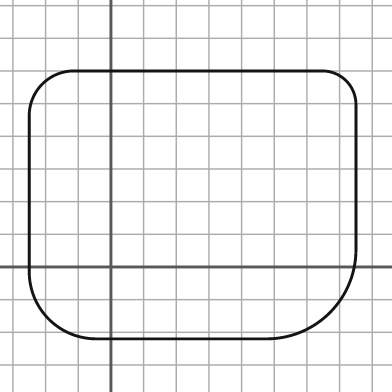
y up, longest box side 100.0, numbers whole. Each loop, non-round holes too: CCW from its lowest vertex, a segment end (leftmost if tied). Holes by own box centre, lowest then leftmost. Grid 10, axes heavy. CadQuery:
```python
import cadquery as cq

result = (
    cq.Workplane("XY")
    .moveTo(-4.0, -22.0)
    .lineTo(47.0, -22.0)
    .threePointArc((67.0, -14.0), (75.0, 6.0))
    .lineTo(75.0, 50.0)
    .threePointArc((72.0, 57.0), (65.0, 60.0))
    .lineTo(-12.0, 60.0)
    .threePointArc((-21.0, 56.0), (-25.0, 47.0))
    .lineTo(-25.0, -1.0)
    .threePointArc((-19.0, -16.0), (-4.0, -22.0))
    .close()
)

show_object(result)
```